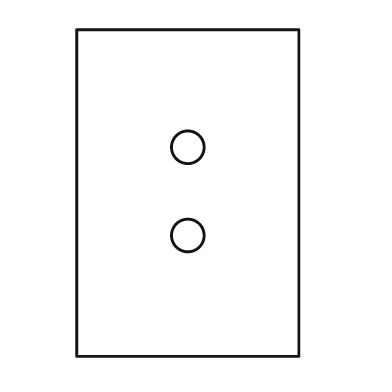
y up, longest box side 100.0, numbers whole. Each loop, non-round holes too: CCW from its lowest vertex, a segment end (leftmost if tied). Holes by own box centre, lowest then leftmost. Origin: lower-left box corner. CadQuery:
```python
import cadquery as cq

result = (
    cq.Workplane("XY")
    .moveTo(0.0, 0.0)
    .lineTo(68.0, 0.0)
    .lineTo(68.0, 100.0)
    .lineTo(0.0, 100.0)
    .close()
    .moveTo(34.0, 37.0)
    .circle(5.0)
    .moveTo(34.0, 64.0)
    .circle(5.0)
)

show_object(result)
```